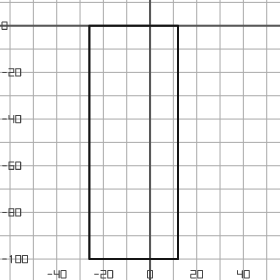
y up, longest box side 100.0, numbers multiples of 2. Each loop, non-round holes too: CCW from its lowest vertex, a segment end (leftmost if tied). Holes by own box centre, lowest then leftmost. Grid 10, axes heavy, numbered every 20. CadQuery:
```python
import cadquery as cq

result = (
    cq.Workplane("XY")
    .moveTo(-26.0, -100.0)
    .lineTo(12.0, -100.0)
    .lineTo(12.0, 0.0)
    .lineTo(-26.0, 0.0)
    .close()
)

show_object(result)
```